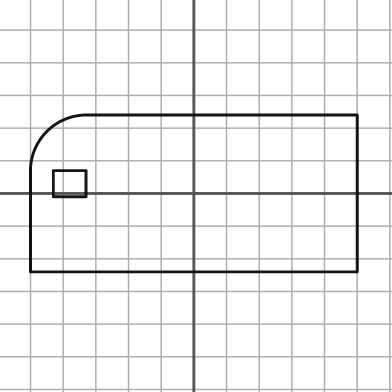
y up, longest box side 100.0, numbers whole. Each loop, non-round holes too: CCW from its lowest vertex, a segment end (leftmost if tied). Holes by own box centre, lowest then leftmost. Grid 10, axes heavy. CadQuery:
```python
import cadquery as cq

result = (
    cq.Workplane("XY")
    .moveTo(-50.0, -24.0)
    .lineTo(50.0, -24.0)
    .lineTo(50.0, 24.0)
    .lineTo(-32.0, 24.0)
    .threePointArc((-45.0, 19.0), (-50.0, 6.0))
    .close()
    .moveTo(-43.0, -1.0)
    .lineTo(-33.0, -1.0)
    .lineTo(-33.0, 7.0)
    .lineTo(-43.0, 7.0)
    .close()
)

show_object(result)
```